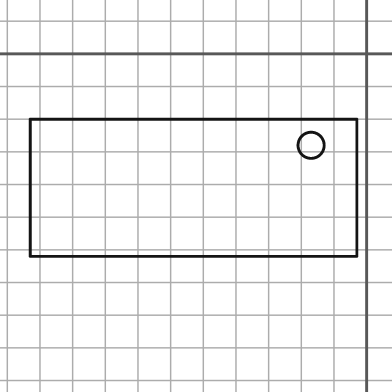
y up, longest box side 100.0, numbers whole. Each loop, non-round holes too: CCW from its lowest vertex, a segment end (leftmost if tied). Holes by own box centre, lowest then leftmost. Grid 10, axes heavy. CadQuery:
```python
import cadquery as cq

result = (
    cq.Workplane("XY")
    .moveTo(-103.0, -62.0)
    .lineTo(-3.0, -62.0)
    .lineTo(-3.0, -20.0)
    .lineTo(-103.0, -20.0)
    .close()
    .moveTo(-17.0, -28.0)
    .circle(4.0)
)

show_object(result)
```